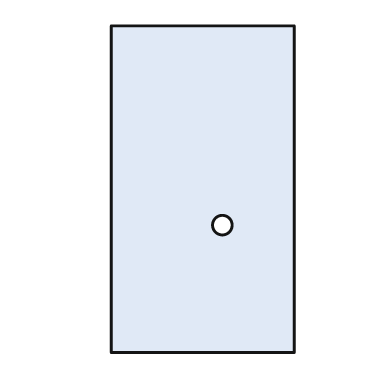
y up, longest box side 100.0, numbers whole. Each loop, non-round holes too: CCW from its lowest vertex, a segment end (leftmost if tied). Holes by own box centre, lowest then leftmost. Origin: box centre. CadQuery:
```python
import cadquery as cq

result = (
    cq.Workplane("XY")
    .moveTo(-28.0, -50.0)
    .lineTo(28.0, -50.0)
    .lineTo(28.0, 50.0)
    .lineTo(-28.0, 50.0)
    .close()
    .moveTo(6.0, -11.0)
    .circle(3.0)
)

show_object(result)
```